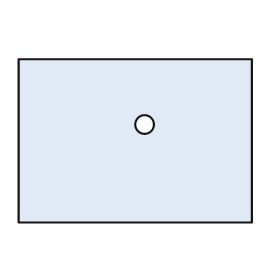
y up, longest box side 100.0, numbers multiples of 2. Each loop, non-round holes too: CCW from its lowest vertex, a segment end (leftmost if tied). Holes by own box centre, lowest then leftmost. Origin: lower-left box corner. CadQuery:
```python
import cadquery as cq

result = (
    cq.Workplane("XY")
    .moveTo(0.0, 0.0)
    .lineTo(100.0, 0.0)
    .lineTo(100.0, 70.0)
    .lineTo(0.0, 70.0)
    .close()
    .moveTo(54.0, 42.0)
    .circle(4.0)
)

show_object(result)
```